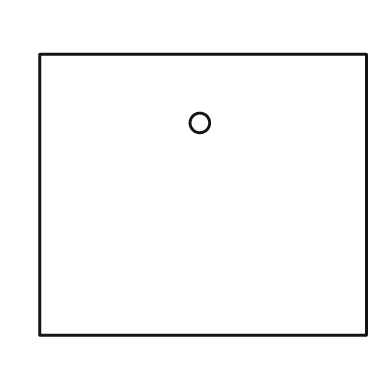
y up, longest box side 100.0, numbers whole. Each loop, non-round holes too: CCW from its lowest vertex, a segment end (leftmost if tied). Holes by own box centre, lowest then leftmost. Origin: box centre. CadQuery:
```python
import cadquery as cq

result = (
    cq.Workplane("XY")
    .moveTo(-50.0, -43.0)
    .lineTo(50.0, -43.0)
    .lineTo(50.0, 43.0)
    .lineTo(-50.0, 43.0)
    .close()
    .moveTo(-1.0, 22.0)
    .circle(3.0)
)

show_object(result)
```